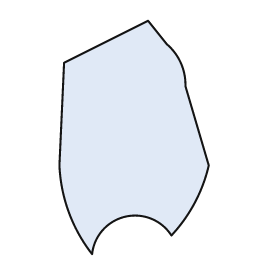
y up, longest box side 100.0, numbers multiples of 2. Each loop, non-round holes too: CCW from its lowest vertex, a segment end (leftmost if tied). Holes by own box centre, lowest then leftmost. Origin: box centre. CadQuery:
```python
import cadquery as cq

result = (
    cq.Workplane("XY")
    .moveTo(-18.0, -50.0)
    .threePointArc((-4.0, -34.0), (16.0, -42.0))
    .threePointArc((26.0, -28.0), (32.0, -12.0))
    .lineTo(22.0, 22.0)
    .threePointArc((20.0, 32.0), (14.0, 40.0))
    .lineTo(6.0, 50.0)
    .lineTo(-30.0, 32.0)
    .lineTo(-32.0, -12.0)
    .threePointArc((-28.0, -32.0), (-18.0, -50.0))
    .close()
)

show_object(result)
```